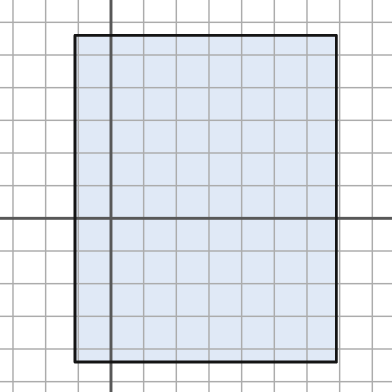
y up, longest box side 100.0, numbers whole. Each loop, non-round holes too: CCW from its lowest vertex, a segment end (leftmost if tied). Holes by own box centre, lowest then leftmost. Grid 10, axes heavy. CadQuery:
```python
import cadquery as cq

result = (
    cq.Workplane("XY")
    .moveTo(-11.0, -44.0)
    .lineTo(69.0, -44.0)
    .lineTo(69.0, 56.0)
    .lineTo(-11.0, 56.0)
    .close()
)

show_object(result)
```